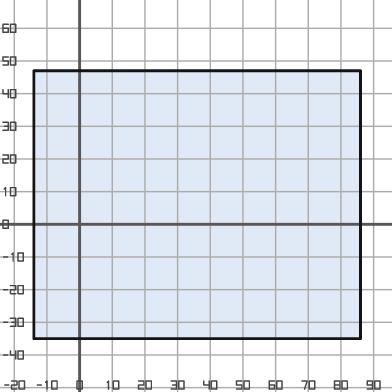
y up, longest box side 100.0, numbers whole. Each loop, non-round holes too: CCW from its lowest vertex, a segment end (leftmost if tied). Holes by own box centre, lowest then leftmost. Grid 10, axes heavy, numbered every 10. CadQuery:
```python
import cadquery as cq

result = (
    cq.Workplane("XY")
    .moveTo(-14.0, -35.0)
    .lineTo(86.0, -35.0)
    .lineTo(86.0, 47.0)
    .lineTo(-14.0, 47.0)
    .close()
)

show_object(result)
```